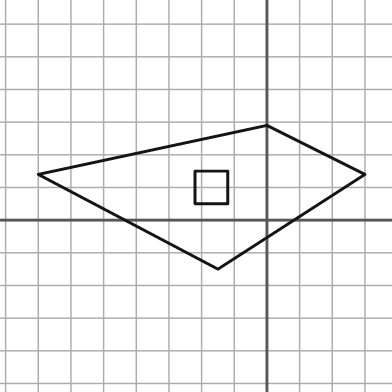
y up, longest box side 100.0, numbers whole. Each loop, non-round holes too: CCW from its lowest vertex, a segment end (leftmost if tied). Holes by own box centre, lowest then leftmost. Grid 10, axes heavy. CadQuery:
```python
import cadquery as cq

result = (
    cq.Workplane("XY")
    .moveTo(-15.0, -15.0)
    .lineTo(30.0, 14.0)
    .lineTo(0.0, 29.0)
    .lineTo(-70.0, 14.0)
    .close()
    .moveTo(-22.0, 5.0)
    .lineTo(-12.0, 5.0)
    .lineTo(-12.0, 15.0)
    .lineTo(-22.0, 15.0)
    .close()
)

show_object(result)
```